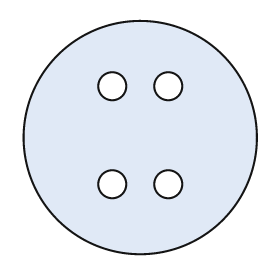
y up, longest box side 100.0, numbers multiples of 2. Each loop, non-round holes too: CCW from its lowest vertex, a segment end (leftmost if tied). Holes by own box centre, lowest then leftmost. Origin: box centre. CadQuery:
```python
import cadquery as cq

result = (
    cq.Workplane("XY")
    .moveTo(0.0, 0.0)
    .circle(50.0)
    .moveTo(-12.0, -20.0)
    .circle(6.0)
    .moveTo(12.0, -20.0)
    .circle(6.0)
    .moveTo(-12.0, 22.0)
    .circle(6.0)
    .moveTo(12.0, 22.0)
    .circle(6.0)
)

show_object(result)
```